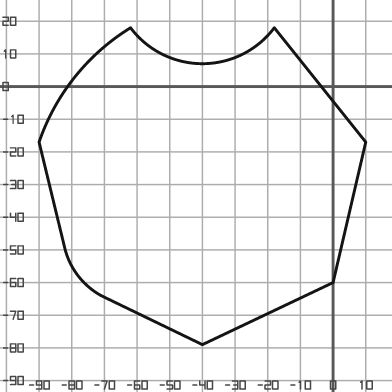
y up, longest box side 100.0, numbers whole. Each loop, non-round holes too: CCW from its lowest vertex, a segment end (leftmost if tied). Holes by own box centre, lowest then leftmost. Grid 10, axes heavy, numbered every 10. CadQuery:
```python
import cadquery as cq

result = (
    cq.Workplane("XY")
    .moveTo(-40.0, -79.0)
    .lineTo(0.0, -60.0)
    .lineTo(10.0, -17.0)
    .lineTo(-18.0, 18.0)
    .threePointArc((-40.0, 7.0), (-62.0, 18.0))
    .threePointArc((-79.0, 3.0), (-90.0, -17.0))
    .lineTo(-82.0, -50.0)
    .threePointArc((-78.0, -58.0), (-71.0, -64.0))
    .close()
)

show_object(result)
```